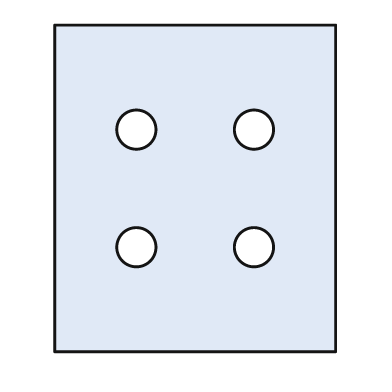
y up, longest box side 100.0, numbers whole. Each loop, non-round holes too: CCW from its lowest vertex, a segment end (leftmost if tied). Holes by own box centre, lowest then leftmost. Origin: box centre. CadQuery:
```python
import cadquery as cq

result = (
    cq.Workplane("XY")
    .moveTo(-43.0, -50.0)
    .lineTo(43.0, -50.0)
    .lineTo(43.0, 50.0)
    .lineTo(-43.0, 50.0)
    .close()
    .moveTo(-18.0, -18.0)
    .circle(6.0)
    .moveTo(18.0, -18.0)
    .circle(6.0)
    .moveTo(-18.0, 18.0)
    .circle(6.0)
    .moveTo(18.0, 18.0)
    .circle(6.0)
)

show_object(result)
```